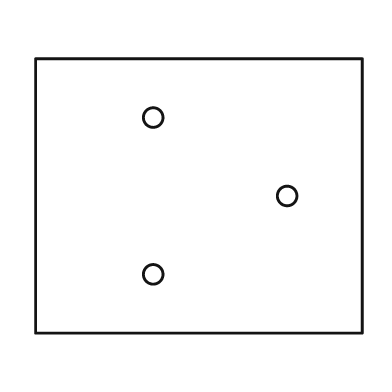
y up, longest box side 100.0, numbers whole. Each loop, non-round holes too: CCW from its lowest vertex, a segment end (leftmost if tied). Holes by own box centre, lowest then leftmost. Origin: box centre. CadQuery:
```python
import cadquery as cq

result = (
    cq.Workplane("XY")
    .moveTo(-50.0, -42.0)
    .lineTo(50.0, -42.0)
    .lineTo(50.0, 42.0)
    .lineTo(-50.0, 42.0)
    .close()
    .moveTo(-14.0, -24.0)
    .circle(3.0)
    .moveTo(27.0, 0.0)
    .circle(3.0)
    .moveTo(-14.0, 24.0)
    .circle(3.0)
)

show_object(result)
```